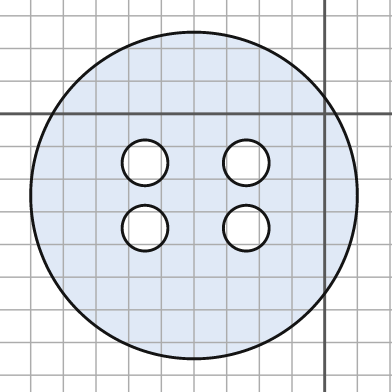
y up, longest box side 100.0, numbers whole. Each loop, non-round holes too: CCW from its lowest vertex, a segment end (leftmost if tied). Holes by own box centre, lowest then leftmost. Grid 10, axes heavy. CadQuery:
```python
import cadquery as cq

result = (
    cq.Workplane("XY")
    .moveTo(-40.0, -25.0)
    .circle(50.0)
    .moveTo(-55.0, -35.0)
    .circle(7.0)
    .moveTo(-24.0, -35.0)
    .circle(7.0)
    .moveTo(-55.0, -15.0)
    .circle(7.0)
    .moveTo(-24.0, -15.0)
    .circle(7.0)
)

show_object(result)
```